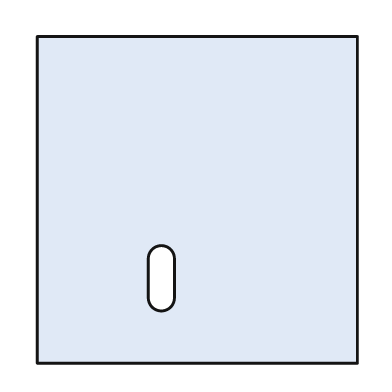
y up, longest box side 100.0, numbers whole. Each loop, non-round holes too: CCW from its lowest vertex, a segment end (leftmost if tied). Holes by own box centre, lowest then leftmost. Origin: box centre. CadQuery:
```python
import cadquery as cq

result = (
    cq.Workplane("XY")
    .moveTo(-49.0, -50.0)
    .lineTo(49.0, -50.0)
    .lineTo(49.0, 50.0)
    .lineTo(-49.0, 50.0)
    .close()
    .moveTo(-15.0, -30.0)
    .threePointArc((-11.0, -34.0), (-7.0, -30.0))
    .lineTo(-7.0, -18.0)
    .threePointArc((-11.0, -14.0), (-15.0, -18.0))
    .close()
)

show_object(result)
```